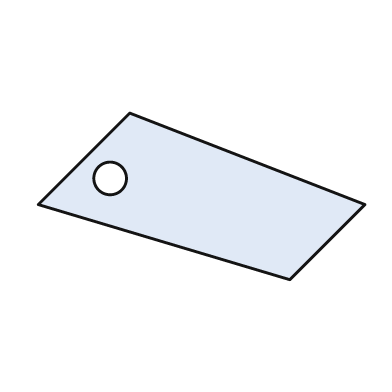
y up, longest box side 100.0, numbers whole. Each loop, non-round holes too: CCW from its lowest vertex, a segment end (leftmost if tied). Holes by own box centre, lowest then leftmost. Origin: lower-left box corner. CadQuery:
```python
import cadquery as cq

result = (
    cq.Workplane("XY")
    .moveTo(77.0, 0.0)
    .lineTo(100.0, 23.0)
    .lineTo(28.0, 51.0)
    .lineTo(0.0, 23.0)
    .close()
    .moveTo(22.0, 31.0)
    .circle(5.0)
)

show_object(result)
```